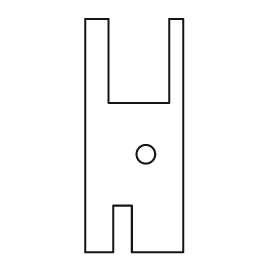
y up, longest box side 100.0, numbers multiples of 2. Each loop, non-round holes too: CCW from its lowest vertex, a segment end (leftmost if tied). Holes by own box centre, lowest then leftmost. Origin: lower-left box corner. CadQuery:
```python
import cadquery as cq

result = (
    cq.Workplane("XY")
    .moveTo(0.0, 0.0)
    .lineTo(12.0, 0.0)
    .lineTo(12.0, 20.0)
    .lineTo(20.0, 20.0)
    .lineTo(20.0, 0.0)
    .lineTo(42.0, 0.0)
    .lineTo(42.0, 100.0)
    .lineTo(36.0, 100.0)
    .lineTo(36.0, 64.0)
    .lineTo(10.0, 64.0)
    .lineTo(10.0, 100.0)
    .lineTo(0.0, 100.0)
    .close()
    .moveTo(26.0, 42.0)
    .circle(4.0)
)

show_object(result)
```